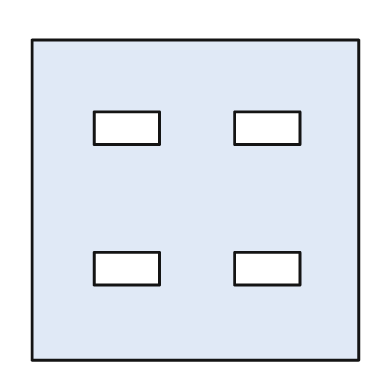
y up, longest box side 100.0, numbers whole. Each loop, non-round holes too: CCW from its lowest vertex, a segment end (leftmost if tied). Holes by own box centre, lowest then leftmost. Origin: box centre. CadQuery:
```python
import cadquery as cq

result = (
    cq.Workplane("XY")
    .moveTo(-50.0, -49.0)
    .lineTo(50.0, -49.0)
    .lineTo(50.0, 49.0)
    .lineTo(-50.0, 49.0)
    .close()
    .moveTo(-31.0, -26.0)
    .lineTo(-11.0, -26.0)
    .lineTo(-11.0, -16.0)
    .lineTo(-31.0, -16.0)
    .close()
    .moveTo(12.0, -26.0)
    .lineTo(32.0, -26.0)
    .lineTo(32.0, -16.0)
    .lineTo(12.0, -16.0)
    .close()
    .moveTo(-31.0, 17.0)
    .lineTo(-11.0, 17.0)
    .lineTo(-11.0, 27.0)
    .lineTo(-31.0, 27.0)
    .close()
    .moveTo(12.0, 17.0)
    .lineTo(32.0, 17.0)
    .lineTo(32.0, 27.0)
    .lineTo(12.0, 27.0)
    .close()
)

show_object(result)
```